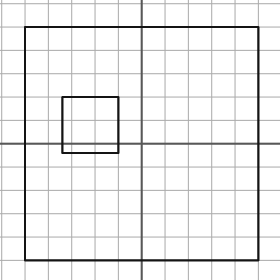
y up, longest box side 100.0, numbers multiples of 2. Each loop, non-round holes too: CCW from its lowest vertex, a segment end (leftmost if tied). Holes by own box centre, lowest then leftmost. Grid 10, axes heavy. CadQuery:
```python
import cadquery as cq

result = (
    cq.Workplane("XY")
    .moveTo(-50.0, -50.0)
    .lineTo(50.0, -50.0)
    .lineTo(50.0, 50.0)
    .lineTo(-50.0, 50.0)
    .close()
    .moveTo(-34.0, -4.0)
    .lineTo(-10.0, -4.0)
    .lineTo(-10.0, 20.0)
    .lineTo(-34.0, 20.0)
    .close()
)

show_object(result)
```